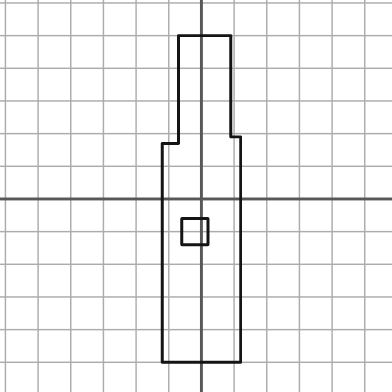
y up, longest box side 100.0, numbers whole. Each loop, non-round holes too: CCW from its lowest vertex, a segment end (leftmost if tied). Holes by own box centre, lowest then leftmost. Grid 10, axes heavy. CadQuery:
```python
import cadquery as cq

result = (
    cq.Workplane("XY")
    .moveTo(-12.0, -50.0)
    .lineTo(12.0, -50.0)
    .lineTo(12.0, 19.0)
    .lineTo(9.0, 19.0)
    .lineTo(9.0, 50.0)
    .lineTo(-7.0, 50.0)
    .lineTo(-7.0, 17.0)
    .lineTo(-12.0, 17.0)
    .close()
    .moveTo(-6.0, -14.0)
    .lineTo(2.0, -14.0)
    .lineTo(2.0, -6.0)
    .lineTo(-6.0, -6.0)
    .close()
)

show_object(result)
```